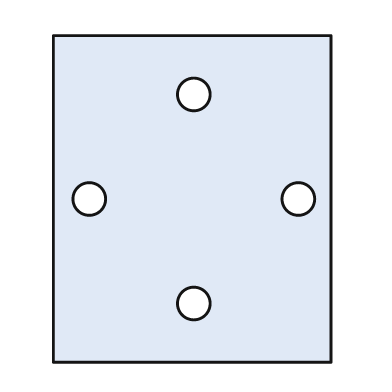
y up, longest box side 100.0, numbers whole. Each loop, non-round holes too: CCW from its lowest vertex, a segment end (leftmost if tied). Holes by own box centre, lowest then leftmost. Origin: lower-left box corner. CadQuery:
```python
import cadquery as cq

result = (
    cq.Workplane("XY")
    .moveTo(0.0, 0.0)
    .lineTo(85.0, 0.0)
    .lineTo(85.0, 100.0)
    .lineTo(0.0, 100.0)
    .close()
    .moveTo(43.0, 18.0)
    .circle(5.0)
    .moveTo(11.0, 50.0)
    .circle(5.0)
    .moveTo(75.0, 50.0)
    .circle(5.0)
    .moveTo(43.0, 82.0)
    .circle(5.0)
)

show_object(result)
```